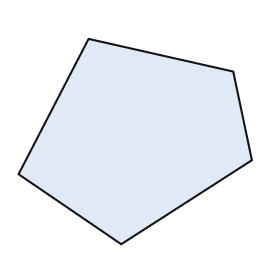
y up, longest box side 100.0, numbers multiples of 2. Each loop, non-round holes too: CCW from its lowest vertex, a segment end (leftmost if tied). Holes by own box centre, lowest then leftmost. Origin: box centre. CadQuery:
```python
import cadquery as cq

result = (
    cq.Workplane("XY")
    .moveTo(-6.0, -44.0)
    .lineTo(50.0, -8.0)
    .lineTo(42.0, 30.0)
    .lineTo(-20.0, 44.0)
    .lineTo(-50.0, -14.0)
    .close()
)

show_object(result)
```